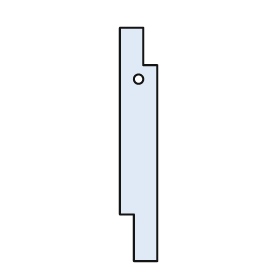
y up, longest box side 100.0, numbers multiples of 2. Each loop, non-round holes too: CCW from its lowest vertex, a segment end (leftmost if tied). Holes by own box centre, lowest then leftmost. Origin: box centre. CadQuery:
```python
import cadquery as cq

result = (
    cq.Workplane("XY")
    .moveTo(-2.0, -50.0)
    .lineTo(8.0, -50.0)
    .lineTo(8.0, 34.0)
    .lineTo(2.0, 34.0)
    .lineTo(2.0, 50.0)
    .lineTo(-8.0, 50.0)
    .lineTo(-8.0, -30.0)
    .lineTo(-2.0, -30.0)
    .close()
    .moveTo(0.0, 28.0)
    .circle(2.0)
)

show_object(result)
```